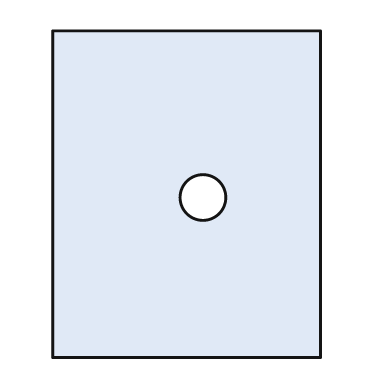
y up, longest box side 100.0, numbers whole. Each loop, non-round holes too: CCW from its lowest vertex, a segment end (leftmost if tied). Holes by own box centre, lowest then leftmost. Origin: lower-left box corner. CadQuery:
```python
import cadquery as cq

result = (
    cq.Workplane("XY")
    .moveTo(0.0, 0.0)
    .lineTo(82.0, 0.0)
    .lineTo(82.0, 100.0)
    .lineTo(0.0, 100.0)
    .close()
    .moveTo(46.0, 49.0)
    .circle(7.0)
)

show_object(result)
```